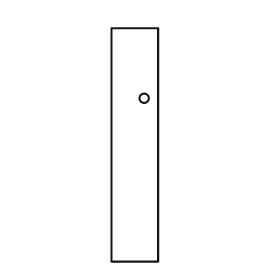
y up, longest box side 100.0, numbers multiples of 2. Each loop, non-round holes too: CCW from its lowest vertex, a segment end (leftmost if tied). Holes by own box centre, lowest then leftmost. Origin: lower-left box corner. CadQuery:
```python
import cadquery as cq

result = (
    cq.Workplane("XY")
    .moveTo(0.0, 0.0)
    .lineTo(20.0, 0.0)
    .lineTo(20.0, 100.0)
    .lineTo(0.0, 100.0)
    .close()
    .moveTo(14.0, 70.0)
    .circle(2.0)
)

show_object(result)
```